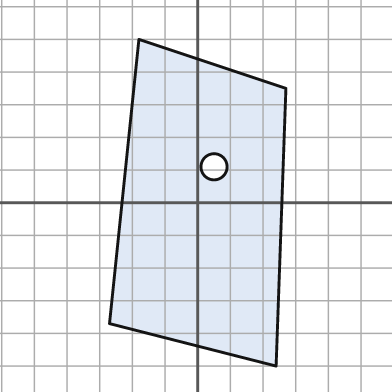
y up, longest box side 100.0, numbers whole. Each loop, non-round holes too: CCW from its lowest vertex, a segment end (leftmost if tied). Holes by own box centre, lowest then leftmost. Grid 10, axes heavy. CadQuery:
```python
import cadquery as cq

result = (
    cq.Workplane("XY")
    .moveTo(24.0, -50.0)
    .lineTo(27.0, 35.0)
    .lineTo(-18.0, 50.0)
    .lineTo(-27.0, -37.0)
    .close()
    .moveTo(5.0, 11.0)
    .circle(4.0)
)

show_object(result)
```